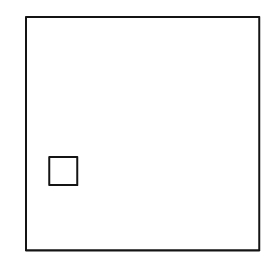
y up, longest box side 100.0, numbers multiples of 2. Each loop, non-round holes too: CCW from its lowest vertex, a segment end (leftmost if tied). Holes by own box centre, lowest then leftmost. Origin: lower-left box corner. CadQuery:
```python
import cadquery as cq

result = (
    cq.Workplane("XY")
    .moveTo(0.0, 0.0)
    .lineTo(100.0, 0.0)
    .lineTo(100.0, 100.0)
    .lineTo(0.0, 100.0)
    .close()
    .moveTo(10.0, 28.0)
    .lineTo(22.0, 28.0)
    .lineTo(22.0, 40.0)
    .lineTo(10.0, 40.0)
    .close()
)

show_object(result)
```